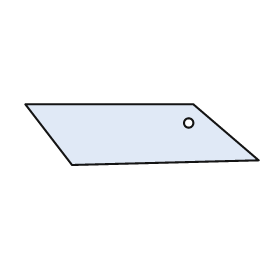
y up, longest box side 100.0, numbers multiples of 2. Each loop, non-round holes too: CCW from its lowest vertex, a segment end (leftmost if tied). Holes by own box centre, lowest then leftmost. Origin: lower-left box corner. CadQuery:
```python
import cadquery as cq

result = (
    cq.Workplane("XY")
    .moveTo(20.0, 0.0)
    .lineTo(100.0, 2.0)
    .lineTo(72.0, 26.0)
    .lineTo(0.0, 26.0)
    .close()
    .moveTo(70.0, 18.0)
    .circle(2.0)
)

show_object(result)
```